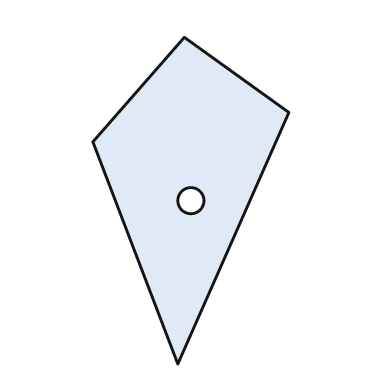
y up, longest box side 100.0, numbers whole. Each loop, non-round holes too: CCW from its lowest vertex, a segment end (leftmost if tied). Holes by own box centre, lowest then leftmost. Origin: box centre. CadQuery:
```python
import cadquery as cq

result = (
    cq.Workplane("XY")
    .moveTo(-4.0, -50.0)
    .lineTo(30.0, 27.0)
    .lineTo(-2.0, 50.0)
    .lineTo(-30.0, 18.0)
    .close()
    .moveTo(0.0, 0.0)
    .circle(4.0)
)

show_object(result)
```